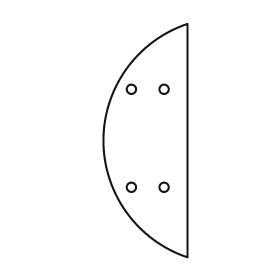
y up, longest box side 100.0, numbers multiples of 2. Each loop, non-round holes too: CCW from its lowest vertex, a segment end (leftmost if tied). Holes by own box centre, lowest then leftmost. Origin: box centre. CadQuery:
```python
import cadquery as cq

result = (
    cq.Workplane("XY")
    .moveTo(18.0, -50.0)
    .lineTo(18.0, 50.0)
    .threePointArc((-18.0, 0.0), (18.0, -50.0))
    .close()
    .moveTo(-6.0, -20.0)
    .circle(2.0)
    .moveTo(8.0, -20.0)
    .circle(2.0)
    .moveTo(-6.0, 22.0)
    .circle(2.0)
    .moveTo(8.0, 22.0)
    .circle(2.0)
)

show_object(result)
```